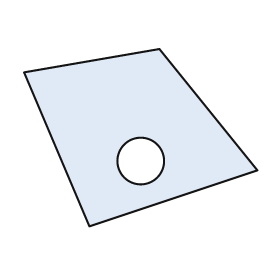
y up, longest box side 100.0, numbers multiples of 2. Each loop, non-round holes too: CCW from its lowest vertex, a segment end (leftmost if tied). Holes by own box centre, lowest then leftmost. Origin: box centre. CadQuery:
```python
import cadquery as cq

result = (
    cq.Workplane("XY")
    .moveTo(-22.0, -38.0)
    .lineTo(50.0, -14.0)
    .lineTo(8.0, 38.0)
    .lineTo(-50.0, 28.0)
    .close()
    .moveTo(0.0, -10.0)
    .circle(10.0)
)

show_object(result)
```